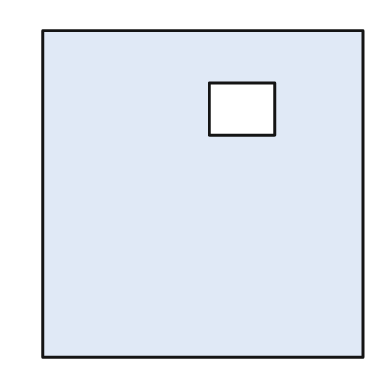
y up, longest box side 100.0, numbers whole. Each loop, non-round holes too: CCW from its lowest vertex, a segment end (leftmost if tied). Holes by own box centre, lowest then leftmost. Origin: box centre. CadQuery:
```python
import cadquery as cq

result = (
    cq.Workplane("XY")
    .moveTo(-49.0, -50.0)
    .lineTo(49.0, -50.0)
    .lineTo(49.0, 50.0)
    .lineTo(-49.0, 50.0)
    .close()
    .moveTo(2.0, 18.0)
    .lineTo(22.0, 18.0)
    .lineTo(22.0, 34.0)
    .lineTo(2.0, 34.0)
    .close()
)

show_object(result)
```